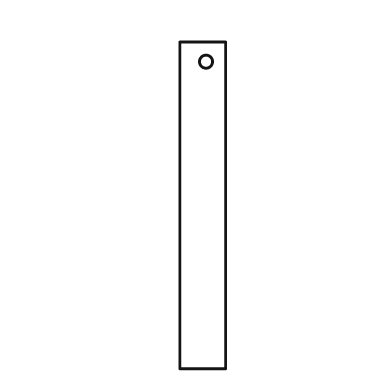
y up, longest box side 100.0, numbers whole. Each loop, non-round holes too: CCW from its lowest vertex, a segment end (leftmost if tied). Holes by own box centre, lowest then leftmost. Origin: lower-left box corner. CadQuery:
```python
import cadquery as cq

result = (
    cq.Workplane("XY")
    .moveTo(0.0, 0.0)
    .lineTo(14.0, 0.0)
    .lineTo(14.0, 100.0)
    .lineTo(0.0, 100.0)
    .close()
    .moveTo(8.0, 94.0)
    .circle(2.0)
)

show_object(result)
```